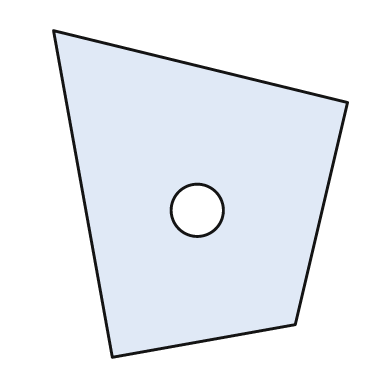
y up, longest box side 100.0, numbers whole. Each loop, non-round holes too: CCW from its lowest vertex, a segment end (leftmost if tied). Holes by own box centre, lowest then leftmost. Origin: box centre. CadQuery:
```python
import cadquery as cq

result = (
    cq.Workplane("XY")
    .moveTo(-27.0, -50.0)
    .lineTo(29.0, -40.0)
    .lineTo(45.0, 28.0)
    .lineTo(-45.0, 50.0)
    .close()
    .moveTo(-1.0, -5.0)
    .circle(8.0)
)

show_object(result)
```